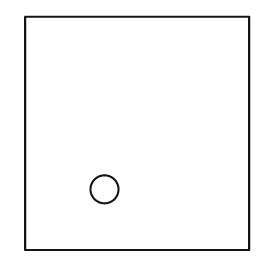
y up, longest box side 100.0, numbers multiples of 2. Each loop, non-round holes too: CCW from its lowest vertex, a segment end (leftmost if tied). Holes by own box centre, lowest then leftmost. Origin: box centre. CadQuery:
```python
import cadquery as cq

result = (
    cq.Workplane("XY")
    .moveTo(-48.0, -50.0)
    .lineTo(48.0, -50.0)
    .lineTo(48.0, 50.0)
    .lineTo(-48.0, 50.0)
    .close()
    .moveTo(-14.0, -24.0)
    .circle(6.0)
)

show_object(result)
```